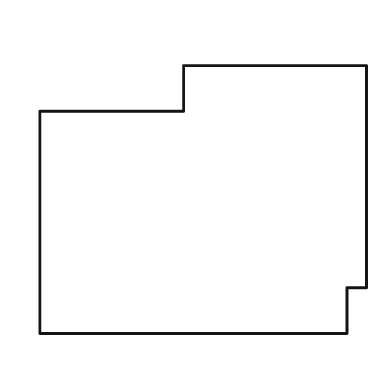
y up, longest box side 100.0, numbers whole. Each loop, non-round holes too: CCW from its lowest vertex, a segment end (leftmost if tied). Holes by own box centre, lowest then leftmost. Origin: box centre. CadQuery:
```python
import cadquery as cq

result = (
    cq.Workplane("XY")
    .moveTo(-50.0, -41.0)
    .lineTo(44.0, -41.0)
    .lineTo(44.0, -27.0)
    .lineTo(50.0, -27.0)
    .lineTo(50.0, 41.0)
    .lineTo(-6.0, 41.0)
    .lineTo(-6.0, 27.0)
    .lineTo(-50.0, 27.0)
    .close()
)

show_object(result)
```